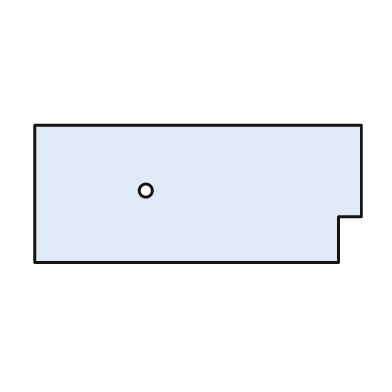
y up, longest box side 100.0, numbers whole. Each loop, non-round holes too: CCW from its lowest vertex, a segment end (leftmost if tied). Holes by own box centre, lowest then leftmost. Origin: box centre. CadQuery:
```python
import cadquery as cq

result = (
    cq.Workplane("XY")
    .moveTo(-50.0, -21.0)
    .lineTo(43.0, -21.0)
    .lineTo(43.0, -7.0)
    .lineTo(50.0, -7.0)
    .lineTo(50.0, 21.0)
    .lineTo(-50.0, 21.0)
    .close()
    .moveTo(-16.0, 1.0)
    .circle(2.0)
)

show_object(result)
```